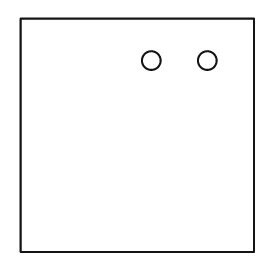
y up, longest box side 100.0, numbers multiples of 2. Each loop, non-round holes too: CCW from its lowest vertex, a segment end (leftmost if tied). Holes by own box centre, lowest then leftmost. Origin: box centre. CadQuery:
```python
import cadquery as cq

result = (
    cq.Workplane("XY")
    .moveTo(-50.0, -50.0)
    .lineTo(50.0, -50.0)
    .lineTo(50.0, 50.0)
    .lineTo(-50.0, 50.0)
    .close()
    .moveTo(6.0, 32.0)
    .circle(4.0)
    .moveTo(30.0, 32.0)
    .circle(4.0)
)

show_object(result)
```